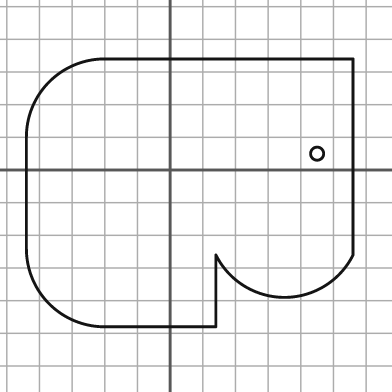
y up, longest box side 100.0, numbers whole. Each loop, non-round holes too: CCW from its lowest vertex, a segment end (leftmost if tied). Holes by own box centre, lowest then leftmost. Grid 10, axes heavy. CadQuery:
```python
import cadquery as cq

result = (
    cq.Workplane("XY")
    .moveTo(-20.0, -48.0)
    .lineTo(14.0, -48.0)
    .lineTo(14.0, -26.0)
    .threePointArc((35.0, -39.0), (56.0, -26.0))
    .lineTo(56.0, 34.0)
    .lineTo(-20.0, 34.0)
    .threePointArc((-37.0, 27.0), (-44.0, 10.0))
    .lineTo(-44.0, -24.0)
    .threePointArc((-37.0, -41.0), (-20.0, -48.0))
    .close()
    .moveTo(45.0, 5.0)
    .circle(2.0)
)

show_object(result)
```